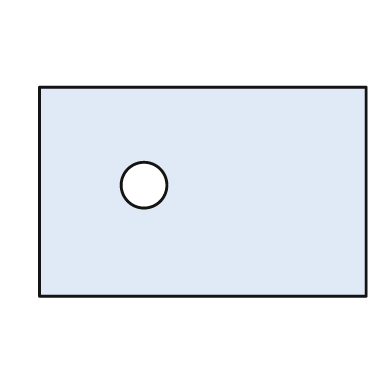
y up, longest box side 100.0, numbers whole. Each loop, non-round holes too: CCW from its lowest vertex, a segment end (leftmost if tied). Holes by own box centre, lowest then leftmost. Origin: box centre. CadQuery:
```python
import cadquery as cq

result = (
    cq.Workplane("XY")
    .moveTo(-50.0, -32.0)
    .lineTo(50.0, -32.0)
    .lineTo(50.0, 32.0)
    .lineTo(-50.0, 32.0)
    .close()
    .moveTo(-18.0, 2.0)
    .circle(7.0)
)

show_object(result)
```